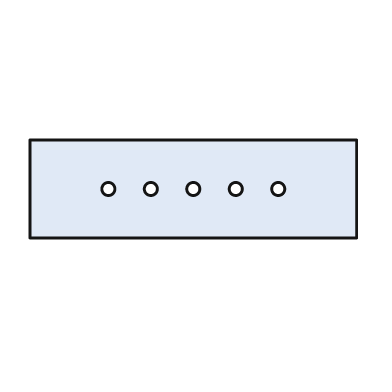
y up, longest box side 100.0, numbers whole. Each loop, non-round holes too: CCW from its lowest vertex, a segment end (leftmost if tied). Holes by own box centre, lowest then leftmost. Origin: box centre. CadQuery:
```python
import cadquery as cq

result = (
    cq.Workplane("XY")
    .moveTo(-50.0, -15.0)
    .lineTo(50.0, -15.0)
    .lineTo(50.0, 15.0)
    .lineTo(-50.0, 15.0)
    .close()
    .moveTo(-26.0, 0.0)
    .circle(2.0)
    .moveTo(-13.0, 0.0)
    .circle(2.0)
    .moveTo(0.0, 0.0)
    .circle(2.0)
    .moveTo(13.0, 0.0)
    .circle(2.0)
    .moveTo(26.0, 0.0)
    .circle(2.0)
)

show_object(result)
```